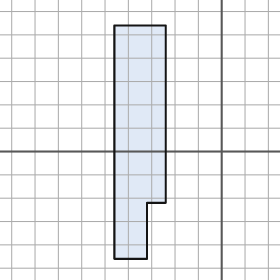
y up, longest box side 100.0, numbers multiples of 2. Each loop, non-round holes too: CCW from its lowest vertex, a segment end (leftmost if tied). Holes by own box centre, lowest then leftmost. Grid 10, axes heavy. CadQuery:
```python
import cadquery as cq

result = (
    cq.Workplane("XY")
    .moveTo(-46.0, -46.0)
    .lineTo(-32.0, -46.0)
    .lineTo(-32.0, -22.0)
    .lineTo(-24.0, -22.0)
    .lineTo(-24.0, 54.0)
    .lineTo(-46.0, 54.0)
    .close()
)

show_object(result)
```